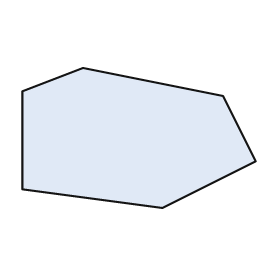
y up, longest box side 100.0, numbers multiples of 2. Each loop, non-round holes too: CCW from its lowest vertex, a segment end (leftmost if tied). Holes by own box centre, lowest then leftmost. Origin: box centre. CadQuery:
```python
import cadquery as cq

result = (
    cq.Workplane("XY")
    .moveTo(10.0, -30.0)
    .lineTo(50.0, -10.0)
    .lineTo(36.0, 18.0)
    .lineTo(-24.0, 30.0)
    .lineTo(-50.0, 20.0)
    .lineTo(-50.0, -22.0)
    .close()
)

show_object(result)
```